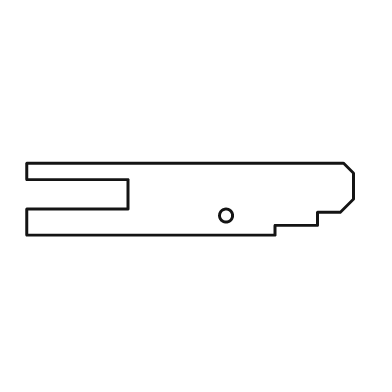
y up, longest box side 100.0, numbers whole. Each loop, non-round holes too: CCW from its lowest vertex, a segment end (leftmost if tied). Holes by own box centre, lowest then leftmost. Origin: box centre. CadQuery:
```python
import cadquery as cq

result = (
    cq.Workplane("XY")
    .moveTo(-50.0, -11.0)
    .lineTo(26.0, -11.0)
    .lineTo(26.0, -8.0)
    .lineTo(39.0, -8.0)
    .lineTo(39.0, -4.0)
    .lineTo(46.0, -4.0)
    .lineTo(50.0, 0.0)
    .lineTo(50.0, 8.0)
    .lineTo(47.0, 11.0)
    .lineTo(-50.0, 11.0)
    .lineTo(-50.0, 6.0)
    .lineTo(-19.0, 6.0)
    .lineTo(-19.0, -3.0)
    .lineTo(-50.0, -3.0)
    .close()
    .moveTo(11.0, -5.0)
    .circle(2.0)
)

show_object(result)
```